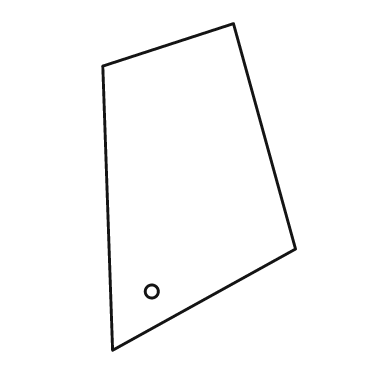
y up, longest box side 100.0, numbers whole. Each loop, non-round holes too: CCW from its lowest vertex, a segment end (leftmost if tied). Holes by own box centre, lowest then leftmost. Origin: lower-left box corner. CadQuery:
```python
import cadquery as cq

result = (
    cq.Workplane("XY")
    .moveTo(3.0, 0.0)
    .lineTo(59.0, 31.0)
    .lineTo(40.0, 100.0)
    .lineTo(0.0, 87.0)
    .close()
    .moveTo(15.0, 18.0)
    .circle(2.0)
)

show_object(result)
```